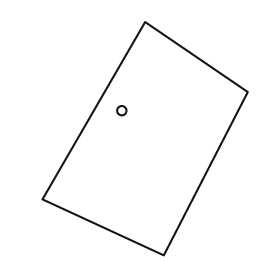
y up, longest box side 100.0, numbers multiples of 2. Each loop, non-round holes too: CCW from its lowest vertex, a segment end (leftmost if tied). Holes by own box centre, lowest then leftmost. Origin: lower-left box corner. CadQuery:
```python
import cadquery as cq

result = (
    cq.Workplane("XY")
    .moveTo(52.0, 0.0)
    .lineTo(88.0, 70.0)
    .lineTo(44.0, 100.0)
    .lineTo(0.0, 24.0)
    .close()
    .moveTo(34.0, 62.0)
    .circle(2.0)
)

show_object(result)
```